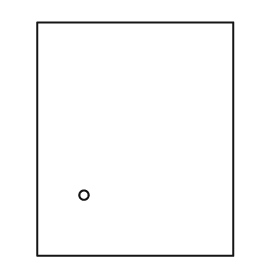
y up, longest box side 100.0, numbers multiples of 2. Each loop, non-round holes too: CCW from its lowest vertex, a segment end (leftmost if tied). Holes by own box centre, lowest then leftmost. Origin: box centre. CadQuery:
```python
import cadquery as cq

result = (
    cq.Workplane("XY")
    .moveTo(-42.0, -50.0)
    .lineTo(42.0, -50.0)
    .lineTo(42.0, 50.0)
    .lineTo(-42.0, 50.0)
    .close()
    .moveTo(-22.0, -24.0)
    .circle(2.0)
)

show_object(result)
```